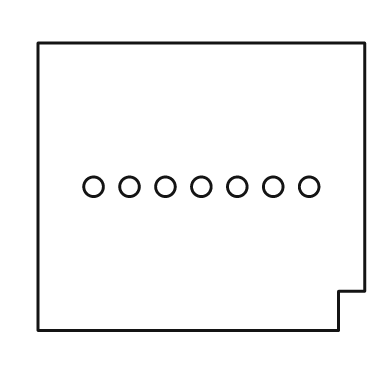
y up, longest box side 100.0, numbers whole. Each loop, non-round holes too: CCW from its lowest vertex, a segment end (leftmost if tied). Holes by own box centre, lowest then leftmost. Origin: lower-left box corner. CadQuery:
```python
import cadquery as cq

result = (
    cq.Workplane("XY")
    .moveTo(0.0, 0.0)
    .lineTo(92.0, 0.0)
    .lineTo(92.0, 12.0)
    .lineTo(100.0, 12.0)
    .lineTo(100.0, 88.0)
    .lineTo(0.0, 88.0)
    .close()
    .moveTo(17.0, 44.0)
    .circle(3.0)
    .moveTo(28.0, 44.0)
    .circle(3.0)
    .moveTo(39.0, 44.0)
    .circle(3.0)
    .moveTo(50.0, 44.0)
    .circle(3.0)
    .moveTo(61.0, 44.0)
    .circle(3.0)
    .moveTo(72.0, 44.0)
    .circle(3.0)
    .moveTo(83.0, 44.0)
    .circle(3.0)
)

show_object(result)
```